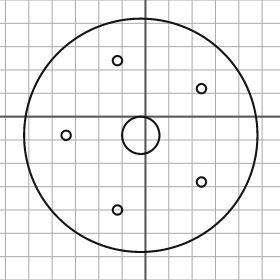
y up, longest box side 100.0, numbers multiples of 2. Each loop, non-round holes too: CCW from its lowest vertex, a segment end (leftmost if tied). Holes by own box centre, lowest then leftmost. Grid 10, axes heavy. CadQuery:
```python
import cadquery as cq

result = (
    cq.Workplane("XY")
    .moveTo(-2.0, -8.0)
    .circle(50.0)
    .moveTo(-12.0, -40.0)
    .circle(2.0)
    .moveTo(24.0, -28.0)
    .circle(2.0)
    .moveTo(-34.0, -8.0)
    .circle(2.0)
    .moveTo(-2.0, -8.0)
    .circle(8.0)
    .moveTo(24.0, 12.0)
    .circle(2.0)
    .moveTo(-12.0, 24.0)
    .circle(2.0)
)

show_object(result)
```